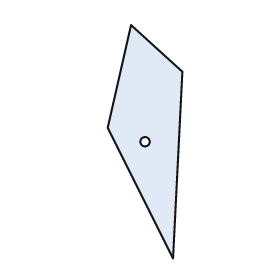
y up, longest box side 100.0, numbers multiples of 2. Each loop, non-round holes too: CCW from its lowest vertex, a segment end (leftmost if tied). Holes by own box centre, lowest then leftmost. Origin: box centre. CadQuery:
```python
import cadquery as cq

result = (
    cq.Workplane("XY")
    .moveTo(12.0, -50.0)
    .lineTo(16.0, 30.0)
    .lineTo(-6.0, 50.0)
    .lineTo(-16.0, 6.0)
    .close()
    .moveTo(0.0, 0.0)
    .circle(2.0)
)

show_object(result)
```